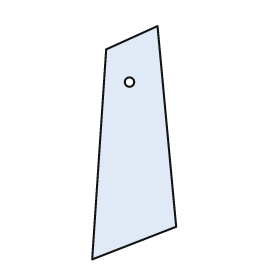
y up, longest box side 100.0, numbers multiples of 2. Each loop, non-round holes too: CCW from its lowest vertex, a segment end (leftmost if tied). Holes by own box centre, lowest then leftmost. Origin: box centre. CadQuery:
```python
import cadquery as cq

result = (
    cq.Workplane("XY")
    .moveTo(-18.0, -50.0)
    .lineTo(18.0, -36.0)
    .lineTo(10.0, 50.0)
    .lineTo(-12.0, 40.0)
    .close()
    .moveTo(-2.0, 26.0)
    .circle(2.0)
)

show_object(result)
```